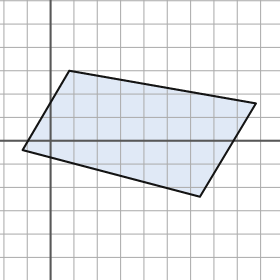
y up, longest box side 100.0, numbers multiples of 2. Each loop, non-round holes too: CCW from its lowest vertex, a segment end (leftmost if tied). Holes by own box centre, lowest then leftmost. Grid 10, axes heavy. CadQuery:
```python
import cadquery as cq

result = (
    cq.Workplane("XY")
    .moveTo(64.0, -24.0)
    .lineTo(88.0, 16.0)
    .lineTo(8.0, 30.0)
    .lineTo(-12.0, -4.0)
    .close()
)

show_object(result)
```